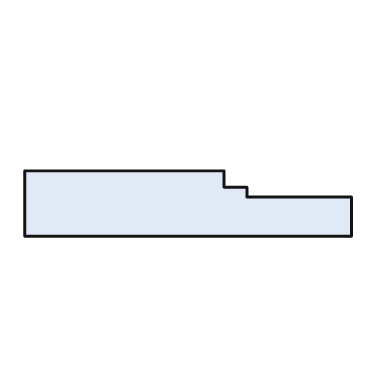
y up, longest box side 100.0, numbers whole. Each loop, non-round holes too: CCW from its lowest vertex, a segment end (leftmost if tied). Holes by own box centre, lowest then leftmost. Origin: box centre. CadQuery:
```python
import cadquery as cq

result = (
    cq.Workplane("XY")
    .moveTo(-50.0, -10.0)
    .lineTo(50.0, -10.0)
    .lineTo(50.0, 2.0)
    .lineTo(18.0, 2.0)
    .lineTo(18.0, 5.0)
    .lineTo(11.0, 5.0)
    .lineTo(11.0, 10.0)
    .lineTo(-50.0, 10.0)
    .close()
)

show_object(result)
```